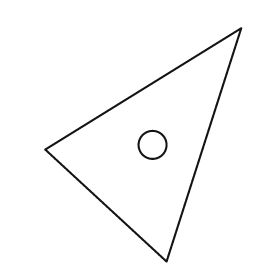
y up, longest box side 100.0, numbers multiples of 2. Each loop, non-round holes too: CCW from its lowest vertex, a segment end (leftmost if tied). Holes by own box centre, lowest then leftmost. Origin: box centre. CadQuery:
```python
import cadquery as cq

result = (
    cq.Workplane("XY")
    .moveTo(10.0, -50.0)
    .lineTo(42.0, 50.0)
    .lineTo(-42.0, -2.0)
    .close()
    .moveTo(4.0, 0.0)
    .circle(6.0)
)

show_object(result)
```